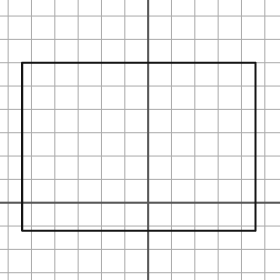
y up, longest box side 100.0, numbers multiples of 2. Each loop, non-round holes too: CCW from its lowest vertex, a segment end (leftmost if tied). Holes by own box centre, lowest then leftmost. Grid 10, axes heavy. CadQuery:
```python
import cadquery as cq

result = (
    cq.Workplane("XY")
    .moveTo(-54.0, -12.0)
    .lineTo(46.0, -12.0)
    .lineTo(46.0, 60.0)
    .lineTo(-54.0, 60.0)
    .close()
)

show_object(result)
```